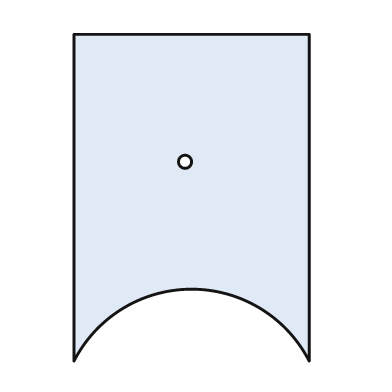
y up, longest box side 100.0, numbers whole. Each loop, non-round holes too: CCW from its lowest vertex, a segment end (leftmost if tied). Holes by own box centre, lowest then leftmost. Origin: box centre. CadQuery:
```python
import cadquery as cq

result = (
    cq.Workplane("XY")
    .moveTo(-36.0, -50.0)
    .threePointArc((0.0, -28.0), (36.0, -50.0))
    .lineTo(36.0, 50.0)
    .lineTo(-36.0, 50.0)
    .close()
    .moveTo(-2.0, 11.0)
    .circle(2.0)
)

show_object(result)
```